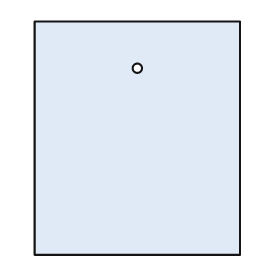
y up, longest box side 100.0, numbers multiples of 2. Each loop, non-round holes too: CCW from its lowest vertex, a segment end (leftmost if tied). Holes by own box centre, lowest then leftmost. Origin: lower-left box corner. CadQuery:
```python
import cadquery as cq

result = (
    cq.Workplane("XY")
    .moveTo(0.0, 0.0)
    .lineTo(88.0, 0.0)
    .lineTo(88.0, 100.0)
    .lineTo(0.0, 100.0)
    .close()
    .moveTo(44.0, 80.0)
    .circle(2.0)
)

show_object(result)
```